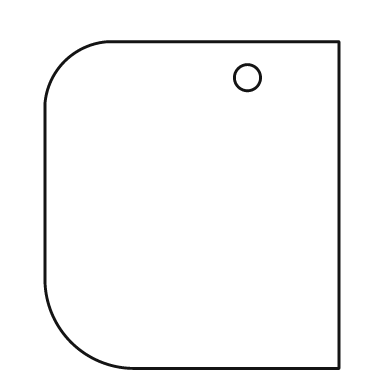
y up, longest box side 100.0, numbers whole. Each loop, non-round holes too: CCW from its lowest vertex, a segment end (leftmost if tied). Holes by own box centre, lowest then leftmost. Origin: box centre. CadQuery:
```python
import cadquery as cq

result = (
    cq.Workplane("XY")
    .moveTo(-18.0, -50.0)
    .lineTo(45.0, -50.0)
    .lineTo(45.0, 50.0)
    .lineTo(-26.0, 50.0)
    .threePointArc((-39.0, 44.0), (-45.0, 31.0))
    .lineTo(-45.0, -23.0)
    .threePointArc((-37.0, -42.0), (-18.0, -50.0))
    .close()
    .moveTo(17.0, 39.0)
    .circle(4.0)
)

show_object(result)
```